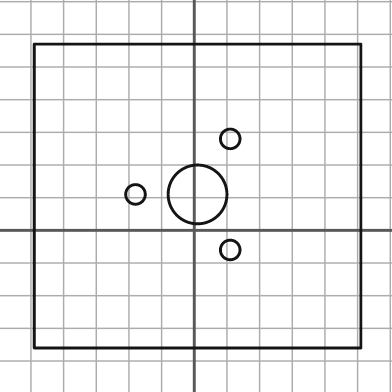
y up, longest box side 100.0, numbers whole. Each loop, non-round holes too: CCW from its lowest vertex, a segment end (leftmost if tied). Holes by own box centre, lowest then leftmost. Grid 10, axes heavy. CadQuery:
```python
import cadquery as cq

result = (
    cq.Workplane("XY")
    .moveTo(-49.0, -36.0)
    .lineTo(51.0, -36.0)
    .lineTo(51.0, 57.0)
    .lineTo(-49.0, 57.0)
    .close()
    .moveTo(11.0, -6.0)
    .circle(3.0)
    .moveTo(-18.0, 11.0)
    .circle(3.0)
    .moveTo(1.0, 11.0)
    .circle(9.0)
    .moveTo(11.0, 28.0)
    .circle(3.0)
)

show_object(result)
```